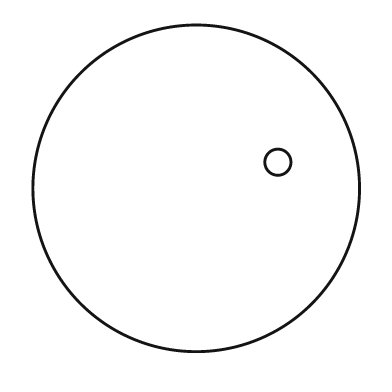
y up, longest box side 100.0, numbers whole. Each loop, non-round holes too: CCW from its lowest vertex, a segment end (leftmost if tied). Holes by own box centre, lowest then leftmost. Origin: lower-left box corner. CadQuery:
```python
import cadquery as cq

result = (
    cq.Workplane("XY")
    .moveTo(50.0, 50.0)
    .circle(50.0)
    .moveTo(75.0, 58.0)
    .circle(4.0)
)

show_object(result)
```